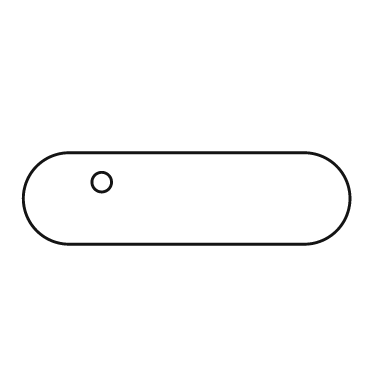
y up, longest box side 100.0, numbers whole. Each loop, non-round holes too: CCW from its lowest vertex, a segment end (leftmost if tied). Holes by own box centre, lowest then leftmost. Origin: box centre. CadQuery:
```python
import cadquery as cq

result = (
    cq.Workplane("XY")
    .moveTo(-36.0, -14.0)
    .lineTo(36.0, -14.0)
    .threePointArc((50.0, 0.0), (36.0, 14.0))
    .lineTo(-36.0, 14.0)
    .threePointArc((-50.0, 0.0), (-36.0, -14.0))
    .close()
    .moveTo(-26.0, 5.0)
    .circle(3.0)
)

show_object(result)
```